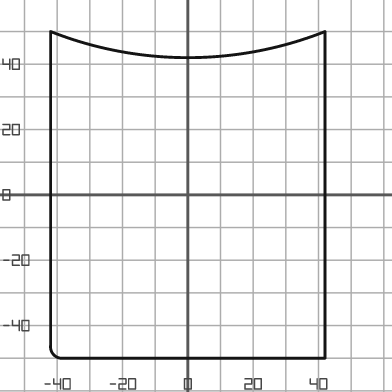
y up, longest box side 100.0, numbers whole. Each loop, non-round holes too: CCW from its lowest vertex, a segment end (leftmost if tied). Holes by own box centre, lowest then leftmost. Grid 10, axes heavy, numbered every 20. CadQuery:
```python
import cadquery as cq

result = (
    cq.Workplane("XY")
    .moveTo(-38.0, -50.0)
    .lineTo(42.0, -50.0)
    .lineTo(42.0, 50.0)
    .threePointArc((0.0, 42.0), (-42.0, 50.0))
    .lineTo(-42.0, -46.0)
    .threePointArc((-41.0, -49.0), (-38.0, -50.0))
    .close()
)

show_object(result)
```